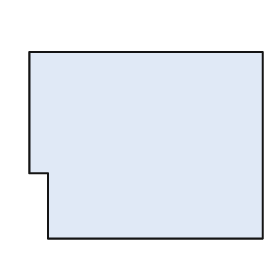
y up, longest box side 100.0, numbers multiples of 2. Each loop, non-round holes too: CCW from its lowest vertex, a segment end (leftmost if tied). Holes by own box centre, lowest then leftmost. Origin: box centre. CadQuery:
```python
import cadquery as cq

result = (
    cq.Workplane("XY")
    .moveTo(-42.0, -40.0)
    .lineTo(50.0, -40.0)
    .lineTo(50.0, 40.0)
    .lineTo(-50.0, 40.0)
    .lineTo(-50.0, -12.0)
    .lineTo(-42.0, -12.0)
    .close()
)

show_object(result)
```